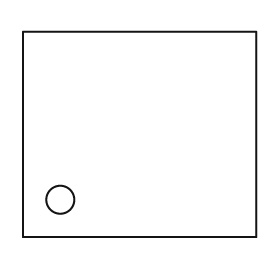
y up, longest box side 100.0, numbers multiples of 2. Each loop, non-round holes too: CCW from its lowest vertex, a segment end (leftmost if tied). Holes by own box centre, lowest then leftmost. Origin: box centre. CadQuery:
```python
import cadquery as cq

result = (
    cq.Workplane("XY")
    .moveTo(-50.0, -44.0)
    .lineTo(50.0, -44.0)
    .lineTo(50.0, 44.0)
    .lineTo(-50.0, 44.0)
    .close()
    .moveTo(-34.0, -28.0)
    .circle(6.0)
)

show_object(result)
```